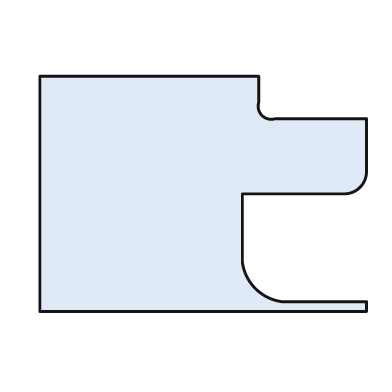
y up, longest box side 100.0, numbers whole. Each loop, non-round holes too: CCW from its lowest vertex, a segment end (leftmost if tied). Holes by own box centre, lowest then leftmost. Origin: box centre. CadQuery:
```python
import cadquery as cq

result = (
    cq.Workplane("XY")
    .moveTo(-50.0, -36.0)
    .lineTo(50.0, -36.0)
    .lineTo(50.0, -33.0)
    .lineTo(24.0, -33.0)
    .threePointArc((16.0, -29.0), (12.0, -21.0))
    .lineTo(12.0, 0.0)
    .lineTo(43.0, 0.0)
    .threePointArc((48.0, 2.0), (50.0, 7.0))
    .lineTo(50.0, 23.0)
    .lineTo(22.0, 23.0)
    .threePointArc((18.0, 24.0), (17.0, 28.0))
    .lineTo(17.0, 36.0)
    .lineTo(-50.0, 36.0)
    .close()
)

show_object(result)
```